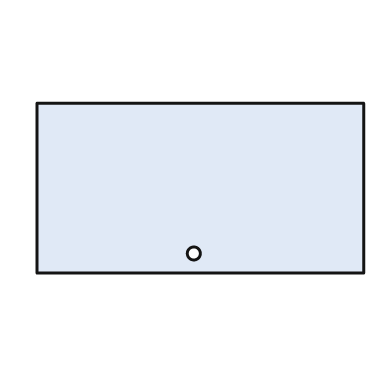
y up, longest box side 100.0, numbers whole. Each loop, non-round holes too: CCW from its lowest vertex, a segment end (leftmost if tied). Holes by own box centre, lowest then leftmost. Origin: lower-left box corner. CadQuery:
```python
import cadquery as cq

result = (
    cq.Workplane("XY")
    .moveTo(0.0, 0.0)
    .lineTo(100.0, 0.0)
    .lineTo(100.0, 52.0)
    .lineTo(0.0, 52.0)
    .close()
    .moveTo(48.0, 6.0)
    .circle(2.0)
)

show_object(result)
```